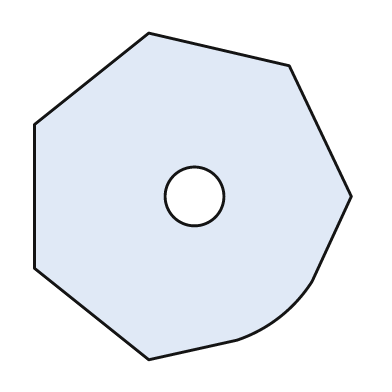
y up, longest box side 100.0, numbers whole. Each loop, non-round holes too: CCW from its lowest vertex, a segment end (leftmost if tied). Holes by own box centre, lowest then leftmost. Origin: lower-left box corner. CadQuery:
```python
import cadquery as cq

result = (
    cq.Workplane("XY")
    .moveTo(35.0, 0.0)
    .lineTo(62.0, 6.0)
    .threePointArc((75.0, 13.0), (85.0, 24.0))
    .lineTo(97.0, 50.0)
    .lineTo(78.0, 90.0)
    .lineTo(35.0, 100.0)
    .lineTo(0.0, 72.0)
    .lineTo(0.0, 28.0)
    .close()
    .moveTo(49.0, 50.0)
    .circle(9.0)
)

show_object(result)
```